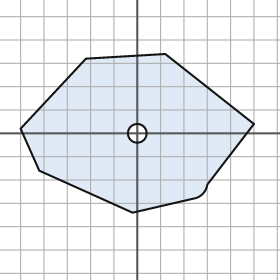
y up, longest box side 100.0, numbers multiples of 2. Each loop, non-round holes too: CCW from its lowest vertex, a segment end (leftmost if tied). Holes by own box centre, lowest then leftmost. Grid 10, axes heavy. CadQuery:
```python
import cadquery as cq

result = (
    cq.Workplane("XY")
    .moveTo(-2.0, -34.0)
    .lineTo(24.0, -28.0)
    .threePointArc((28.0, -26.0), (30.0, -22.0))
    .lineTo(50.0, 4.0)
    .lineTo(12.0, 34.0)
    .lineTo(-22.0, 32.0)
    .lineTo(-50.0, 2.0)
    .lineTo(-42.0, -16.0)
    .close()
    .moveTo(0.0, 0.0)
    .circle(4.0)
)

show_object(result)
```